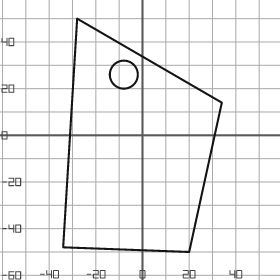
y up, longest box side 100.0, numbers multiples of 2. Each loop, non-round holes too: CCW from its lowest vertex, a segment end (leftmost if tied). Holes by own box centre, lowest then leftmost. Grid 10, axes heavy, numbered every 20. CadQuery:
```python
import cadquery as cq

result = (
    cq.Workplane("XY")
    .moveTo(20.0, -50.0)
    .lineTo(34.0, 14.0)
    .lineTo(-28.0, 50.0)
    .lineTo(-34.0, -48.0)
    .close()
    .moveTo(-8.0, 26.0)
    .circle(6.0)
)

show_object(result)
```